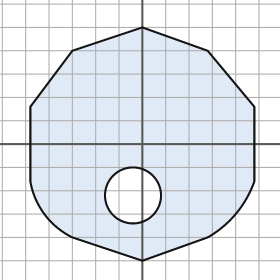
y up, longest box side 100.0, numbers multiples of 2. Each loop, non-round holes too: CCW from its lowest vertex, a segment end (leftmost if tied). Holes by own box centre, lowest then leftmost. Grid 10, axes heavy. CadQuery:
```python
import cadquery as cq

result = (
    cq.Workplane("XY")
    .moveTo(0.0, -50.0)
    .lineTo(28.0, -40.0)
    .threePointArc((40.0, -30.0), (48.0, -16.0))
    .lineTo(48.0, 16.0)
    .lineTo(28.0, 40.0)
    .lineTo(0.0, 50.0)
    .lineTo(-30.0, 40.0)
    .lineTo(-48.0, 16.0)
    .lineTo(-48.0, -16.0)
    .threePointArc((-42.0, -30.0), (-30.0, -40.0))
    .close()
    .moveTo(-4.0, -22.0)
    .circle(12.0)
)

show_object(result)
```